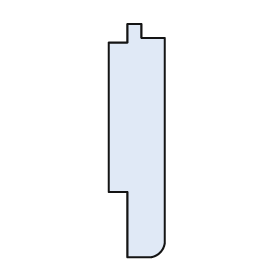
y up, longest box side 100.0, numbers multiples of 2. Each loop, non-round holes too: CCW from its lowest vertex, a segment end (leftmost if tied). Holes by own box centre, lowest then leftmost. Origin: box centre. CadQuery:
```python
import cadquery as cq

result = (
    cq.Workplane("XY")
    .moveTo(-4.0, -50.0)
    .lineTo(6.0, -50.0)
    .threePointArc((10.0, -48.0), (12.0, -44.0))
    .lineTo(12.0, 44.0)
    .lineTo(2.0, 44.0)
    .lineTo(2.0, 50.0)
    .lineTo(-4.0, 50.0)
    .lineTo(-4.0, 42.0)
    .lineTo(-12.0, 42.0)
    .lineTo(-12.0, -22.0)
    .lineTo(-4.0, -22.0)
    .close()
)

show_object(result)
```